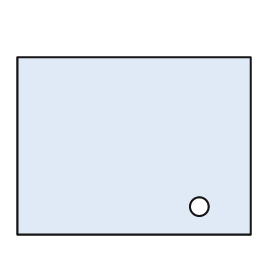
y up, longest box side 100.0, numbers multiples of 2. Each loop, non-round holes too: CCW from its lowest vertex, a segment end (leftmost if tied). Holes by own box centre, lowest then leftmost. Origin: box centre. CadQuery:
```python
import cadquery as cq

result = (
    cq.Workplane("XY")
    .moveTo(-50.0, -38.0)
    .lineTo(50.0, -38.0)
    .lineTo(50.0, 38.0)
    .lineTo(-50.0, 38.0)
    .close()
    .moveTo(28.0, -26.0)
    .circle(4.0)
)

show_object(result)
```